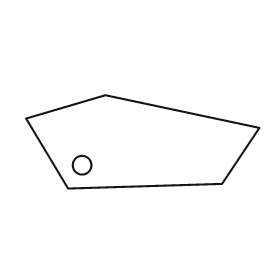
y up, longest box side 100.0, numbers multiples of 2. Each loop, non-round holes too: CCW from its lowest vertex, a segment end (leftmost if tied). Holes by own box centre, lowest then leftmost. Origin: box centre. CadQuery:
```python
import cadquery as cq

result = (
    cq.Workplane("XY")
    .moveTo(-32.0, -20.0)
    .lineTo(34.0, -18.0)
    .lineTo(50.0, 6.0)
    .lineTo(-16.0, 20.0)
    .lineTo(-50.0, 10.0)
    .close()
    .moveTo(-26.0, -10.0)
    .circle(4.0)
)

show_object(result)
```